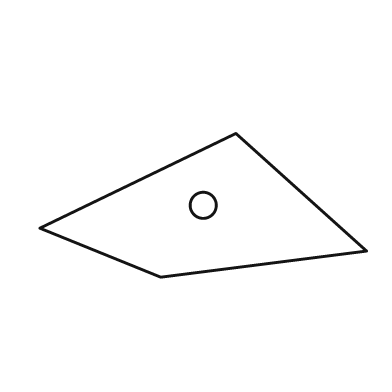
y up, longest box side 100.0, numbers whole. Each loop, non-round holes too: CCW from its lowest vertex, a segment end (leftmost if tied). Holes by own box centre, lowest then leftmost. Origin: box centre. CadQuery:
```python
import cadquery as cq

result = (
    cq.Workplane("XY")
    .moveTo(-13.0, -22.0)
    .lineTo(50.0, -14.0)
    .lineTo(10.0, 22.0)
    .lineTo(-50.0, -7.0)
    .close()
    .moveTo(0.0, 0.0)
    .circle(4.0)
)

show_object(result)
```